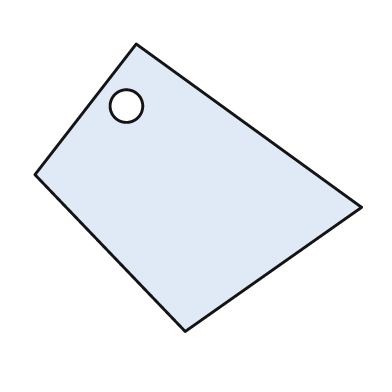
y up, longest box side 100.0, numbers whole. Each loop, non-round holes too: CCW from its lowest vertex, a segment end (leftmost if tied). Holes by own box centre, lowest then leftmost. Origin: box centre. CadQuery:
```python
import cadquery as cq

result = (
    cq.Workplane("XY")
    .moveTo(-4.0, -44.0)
    .lineTo(50.0, -6.0)
    .lineTo(-19.0, 44.0)
    .lineTo(-50.0, 4.0)
    .close()
    .moveTo(-22.0, 25.0)
    .circle(5.0)
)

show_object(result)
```